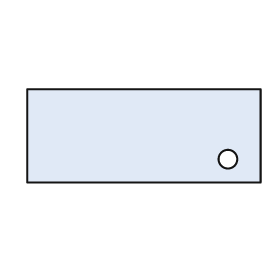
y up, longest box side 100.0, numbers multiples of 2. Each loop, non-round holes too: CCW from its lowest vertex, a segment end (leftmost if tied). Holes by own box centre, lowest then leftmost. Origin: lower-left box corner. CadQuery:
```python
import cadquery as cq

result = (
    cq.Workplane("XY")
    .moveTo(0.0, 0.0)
    .lineTo(100.0, 0.0)
    .lineTo(100.0, 40.0)
    .lineTo(0.0, 40.0)
    .close()
    .moveTo(86.0, 10.0)
    .circle(4.0)
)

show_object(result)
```